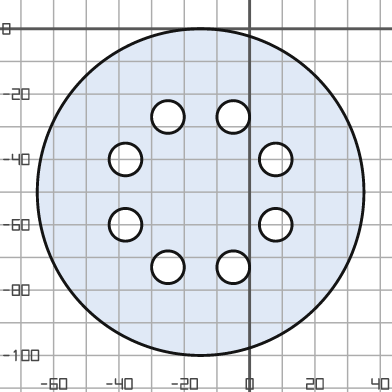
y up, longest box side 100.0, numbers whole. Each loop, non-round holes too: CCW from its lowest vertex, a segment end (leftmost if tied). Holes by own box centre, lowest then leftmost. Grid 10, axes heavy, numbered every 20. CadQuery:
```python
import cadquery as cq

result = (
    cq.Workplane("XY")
    .moveTo(-15.0, -50.0)
    .circle(50.0)
    .moveTo(-25.0, -73.0)
    .circle(5.0)
    .moveTo(-5.0, -73.0)
    .circle(5.0)
    .moveTo(-38.0, -60.0)
    .circle(5.0)
    .moveTo(8.0, -60.0)
    .circle(5.0)
    .moveTo(-38.0, -40.0)
    .circle(5.0)
    .moveTo(8.0, -40.0)
    .circle(5.0)
    .moveTo(-25.0, -27.0)
    .circle(5.0)
    .moveTo(-5.0, -27.0)
    .circle(5.0)
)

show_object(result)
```